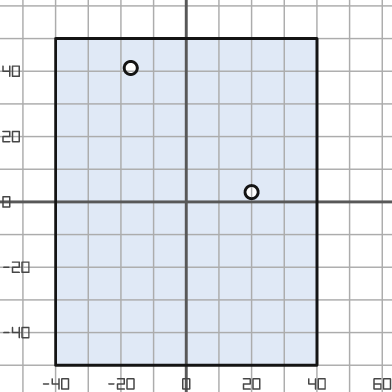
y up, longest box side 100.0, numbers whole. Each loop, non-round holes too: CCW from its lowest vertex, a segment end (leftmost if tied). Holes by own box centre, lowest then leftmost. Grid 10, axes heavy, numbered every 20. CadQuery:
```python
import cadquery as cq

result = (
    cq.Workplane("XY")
    .moveTo(-40.0, -50.0)
    .lineTo(40.0, -50.0)
    .lineTo(40.0, 50.0)
    .lineTo(-40.0, 50.0)
    .close()
    .moveTo(20.0, 3.0)
    .circle(2.0)
    .moveTo(-17.0, 41.0)
    .circle(2.0)
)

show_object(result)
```